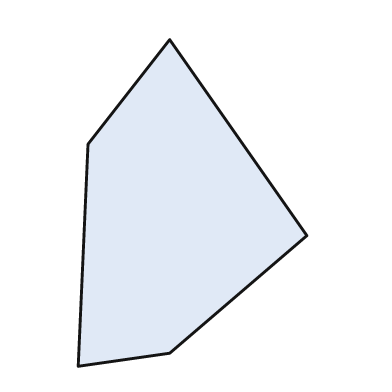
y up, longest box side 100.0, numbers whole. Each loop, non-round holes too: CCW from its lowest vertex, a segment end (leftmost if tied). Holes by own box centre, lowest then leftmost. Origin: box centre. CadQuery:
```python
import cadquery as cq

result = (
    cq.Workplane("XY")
    .moveTo(-35.0, -50.0)
    .lineTo(-7.0, -46.0)
    .lineTo(35.0, -10.0)
    .lineTo(-7.0, 50.0)
    .lineTo(-32.0, 18.0)
    .close()
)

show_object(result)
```